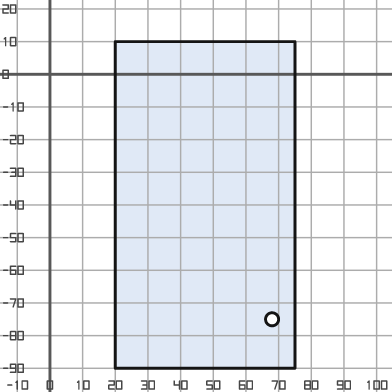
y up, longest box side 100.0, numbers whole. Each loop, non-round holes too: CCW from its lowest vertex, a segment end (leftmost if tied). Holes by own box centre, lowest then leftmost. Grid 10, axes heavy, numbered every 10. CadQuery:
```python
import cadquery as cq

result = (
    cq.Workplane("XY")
    .moveTo(20.0, -90.0)
    .lineTo(75.0, -90.0)
    .lineTo(75.0, 10.0)
    .lineTo(20.0, 10.0)
    .close()
    .moveTo(68.0, -75.0)
    .circle(2.0)
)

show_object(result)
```